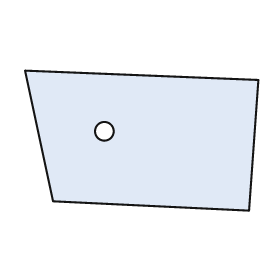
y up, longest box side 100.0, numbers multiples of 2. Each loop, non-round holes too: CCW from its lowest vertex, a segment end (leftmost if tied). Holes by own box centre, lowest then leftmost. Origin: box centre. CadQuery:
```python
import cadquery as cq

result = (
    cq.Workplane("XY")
    .moveTo(46.0, -30.0)
    .lineTo(50.0, 26.0)
    .lineTo(-50.0, 30.0)
    .lineTo(-38.0, -26.0)
    .close()
    .moveTo(-16.0, 4.0)
    .circle(4.0)
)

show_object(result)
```